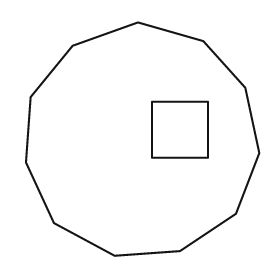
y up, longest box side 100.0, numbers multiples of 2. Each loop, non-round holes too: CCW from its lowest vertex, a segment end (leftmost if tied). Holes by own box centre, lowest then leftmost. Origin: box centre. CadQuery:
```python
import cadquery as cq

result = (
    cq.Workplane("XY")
    .moveTo(-12.0, -50.0)
    .lineTo(16.0, -48.0)
    .lineTo(40.0, -32.0)
    .lineTo(50.0, -6.0)
    .lineTo(44.0, 22.0)
    .lineTo(26.0, 42.0)
    .lineTo(-2.0, 50.0)
    .lineTo(-30.0, 40.0)
    .lineTo(-48.0, 18.0)
    .lineTo(-50.0, -10.0)
    .lineTo(-38.0, -36.0)
    .close()
    .moveTo(4.0, -8.0)
    .lineTo(28.0, -8.0)
    .lineTo(28.0, 16.0)
    .lineTo(4.0, 16.0)
    .close()
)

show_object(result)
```